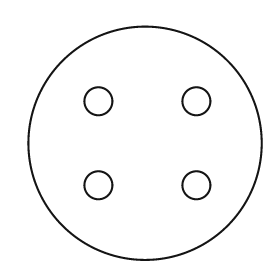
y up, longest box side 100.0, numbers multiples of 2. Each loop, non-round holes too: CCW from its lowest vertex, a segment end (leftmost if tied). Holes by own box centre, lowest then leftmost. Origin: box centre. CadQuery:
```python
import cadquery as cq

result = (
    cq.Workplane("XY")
    .moveTo(0.0, 0.0)
    .circle(50.0)
    .moveTo(-20.0, -18.0)
    .circle(6.0)
    .moveTo(22.0, -18.0)
    .circle(6.0)
    .moveTo(-20.0, 18.0)
    .circle(6.0)
    .moveTo(22.0, 18.0)
    .circle(6.0)
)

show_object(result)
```